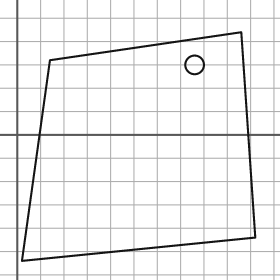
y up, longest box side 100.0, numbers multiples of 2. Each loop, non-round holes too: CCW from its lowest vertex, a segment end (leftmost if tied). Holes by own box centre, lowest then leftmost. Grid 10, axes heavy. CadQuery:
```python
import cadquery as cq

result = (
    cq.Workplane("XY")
    .moveTo(2.0, -54.0)
    .lineTo(102.0, -44.0)
    .lineTo(96.0, 44.0)
    .lineTo(14.0, 32.0)
    .close()
    .moveTo(76.0, 30.0)
    .circle(4.0)
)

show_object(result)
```